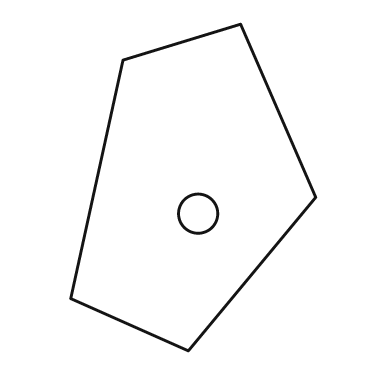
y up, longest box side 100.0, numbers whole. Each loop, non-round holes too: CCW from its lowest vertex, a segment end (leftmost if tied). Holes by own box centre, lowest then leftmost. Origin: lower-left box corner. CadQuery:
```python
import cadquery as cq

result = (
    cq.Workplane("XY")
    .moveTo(36.0, 0.0)
    .lineTo(75.0, 47.0)
    .lineTo(52.0, 100.0)
    .lineTo(16.0, 89.0)
    .lineTo(0.0, 16.0)
    .close()
    .moveTo(39.0, 42.0)
    .circle(6.0)
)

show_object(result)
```